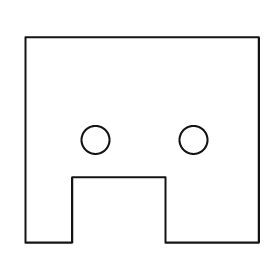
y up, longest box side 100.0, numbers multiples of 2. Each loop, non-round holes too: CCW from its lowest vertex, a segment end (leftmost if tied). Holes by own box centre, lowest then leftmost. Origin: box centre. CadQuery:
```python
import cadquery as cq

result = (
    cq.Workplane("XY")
    .moveTo(-50.0, -44.0)
    .lineTo(-30.0, -44.0)
    .lineTo(-30.0, -16.0)
    .lineTo(10.0, -16.0)
    .lineTo(10.0, -44.0)
    .lineTo(50.0, -44.0)
    .lineTo(50.0, 44.0)
    .lineTo(-50.0, 44.0)
    .close()
    .moveTo(-20.0, 0.0)
    .circle(6.0)
    .moveTo(22.0, 0.0)
    .circle(6.0)
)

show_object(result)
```